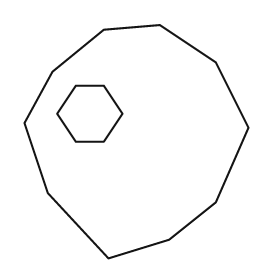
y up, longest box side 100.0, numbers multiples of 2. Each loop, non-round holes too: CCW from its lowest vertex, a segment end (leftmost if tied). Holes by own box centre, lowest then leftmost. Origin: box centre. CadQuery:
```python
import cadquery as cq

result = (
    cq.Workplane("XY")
    .moveTo(-12.0, -50.0)
    .lineTo(14.0, -42.0)
    .lineTo(34.0, -26.0)
    .lineTo(48.0, 6.0)
    .lineTo(34.0, 34.0)
    .lineTo(10.0, 50.0)
    .lineTo(-14.0, 48.0)
    .lineTo(-36.0, 30.0)
    .lineTo(-48.0, 8.0)
    .lineTo(-38.0, -22.0)
    .close()
    .moveTo(-26.0, 0.0)
    .lineTo(-14.0, 0.0)
    .lineTo(-6.0, 12.0)
    .lineTo(-14.0, 24.0)
    .lineTo(-26.0, 24.0)
    .lineTo(-34.0, 12.0)
    .close()
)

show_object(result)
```